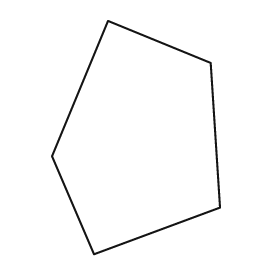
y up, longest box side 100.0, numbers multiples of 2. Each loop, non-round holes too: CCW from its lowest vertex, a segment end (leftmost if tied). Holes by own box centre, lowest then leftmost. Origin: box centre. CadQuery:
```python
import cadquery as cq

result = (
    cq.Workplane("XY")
    .moveTo(-18.0, -50.0)
    .lineTo(36.0, -30.0)
    .lineTo(32.0, 32.0)
    .lineTo(-12.0, 50.0)
    .lineTo(-36.0, -8.0)
    .close()
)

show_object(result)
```